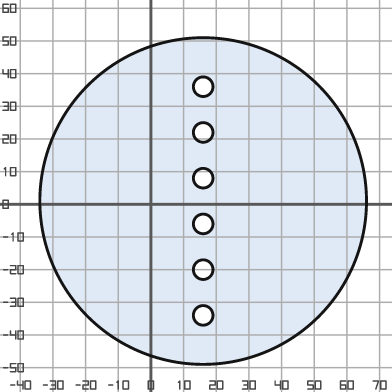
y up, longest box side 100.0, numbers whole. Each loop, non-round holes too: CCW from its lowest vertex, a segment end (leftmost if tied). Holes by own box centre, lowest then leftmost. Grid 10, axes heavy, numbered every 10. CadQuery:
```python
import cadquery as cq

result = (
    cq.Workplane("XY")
    .moveTo(16.0, 1.0)
    .circle(50.0)
    .moveTo(16.0, -34.0)
    .circle(3.0)
    .moveTo(16.0, -20.0)
    .circle(3.0)
    .moveTo(16.0, -6.0)
    .circle(3.0)
    .moveTo(16.0, 8.0)
    .circle(3.0)
    .moveTo(16.0, 22.0)
    .circle(3.0)
    .moveTo(16.0, 36.0)
    .circle(3.0)
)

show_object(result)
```